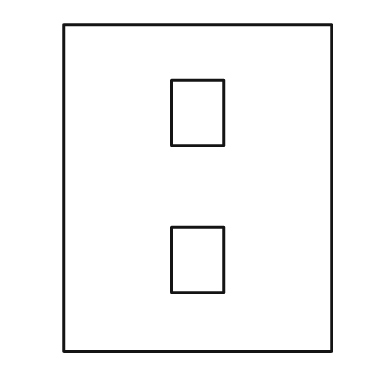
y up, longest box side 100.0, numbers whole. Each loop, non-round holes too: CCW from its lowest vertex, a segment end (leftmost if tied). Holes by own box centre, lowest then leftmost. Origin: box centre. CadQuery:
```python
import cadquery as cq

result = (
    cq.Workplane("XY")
    .moveTo(-41.0, -50.0)
    .lineTo(41.0, -50.0)
    .lineTo(41.0, 50.0)
    .lineTo(-41.0, 50.0)
    .close()
    .moveTo(-8.0, -32.0)
    .lineTo(8.0, -32.0)
    .lineTo(8.0, -12.0)
    .lineTo(-8.0, -12.0)
    .close()
    .moveTo(-8.0, 13.0)
    .lineTo(8.0, 13.0)
    .lineTo(8.0, 33.0)
    .lineTo(-8.0, 33.0)
    .close()
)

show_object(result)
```